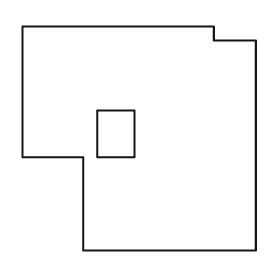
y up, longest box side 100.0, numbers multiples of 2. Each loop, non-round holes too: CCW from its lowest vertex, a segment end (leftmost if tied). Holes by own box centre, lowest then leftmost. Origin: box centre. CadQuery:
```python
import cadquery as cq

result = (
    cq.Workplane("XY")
    .moveTo(-24.0, -48.0)
    .lineTo(50.0, -48.0)
    .lineTo(50.0, 42.0)
    .lineTo(32.0, 42.0)
    .lineTo(32.0, 48.0)
    .lineTo(-50.0, 48.0)
    .lineTo(-50.0, -8.0)
    .lineTo(-24.0, -8.0)
    .close()
    .moveTo(-18.0, -8.0)
    .lineTo(-2.0, -8.0)
    .lineTo(-2.0, 12.0)
    .lineTo(-18.0, 12.0)
    .close()
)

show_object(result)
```